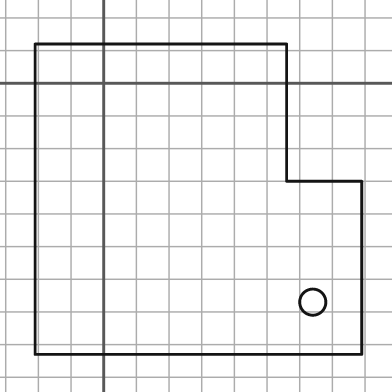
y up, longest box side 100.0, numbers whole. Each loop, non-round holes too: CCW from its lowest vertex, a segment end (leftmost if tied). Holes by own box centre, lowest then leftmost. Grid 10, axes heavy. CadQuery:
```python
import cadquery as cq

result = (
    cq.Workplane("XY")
    .moveTo(-21.0, -83.0)
    .lineTo(79.0, -83.0)
    .lineTo(79.0, -30.0)
    .lineTo(56.0, -30.0)
    .lineTo(56.0, 12.0)
    .lineTo(-21.0, 12.0)
    .close()
    .moveTo(64.0, -67.0)
    .circle(4.0)
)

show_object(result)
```